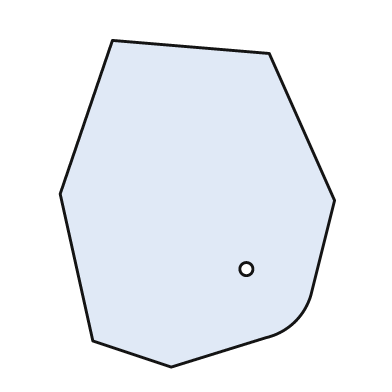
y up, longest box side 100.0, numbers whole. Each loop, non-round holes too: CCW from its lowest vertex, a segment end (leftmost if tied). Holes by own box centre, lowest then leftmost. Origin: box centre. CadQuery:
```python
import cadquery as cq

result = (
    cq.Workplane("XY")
    .moveTo(-8.0, -50.0)
    .lineTo(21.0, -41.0)
    .threePointArc((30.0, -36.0), (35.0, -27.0))
    .lineTo(42.0, 1.0)
    .lineTo(22.0, 46.0)
    .lineTo(-26.0, 50.0)
    .lineTo(-42.0, 3.0)
    .lineTo(-32.0, -42.0)
    .close()
    .moveTo(15.0, -20.0)
    .circle(2.0)
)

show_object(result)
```